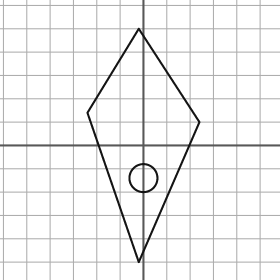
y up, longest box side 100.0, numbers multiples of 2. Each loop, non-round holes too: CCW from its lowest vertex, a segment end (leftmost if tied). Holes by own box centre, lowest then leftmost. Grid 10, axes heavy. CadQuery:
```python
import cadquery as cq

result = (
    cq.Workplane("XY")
    .moveTo(-2.0, -50.0)
    .lineTo(24.0, 10.0)
    .lineTo(-2.0, 50.0)
    .lineTo(-24.0, 14.0)
    .close()
    .moveTo(0.0, -14.0)
    .circle(6.0)
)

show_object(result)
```